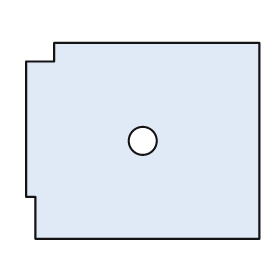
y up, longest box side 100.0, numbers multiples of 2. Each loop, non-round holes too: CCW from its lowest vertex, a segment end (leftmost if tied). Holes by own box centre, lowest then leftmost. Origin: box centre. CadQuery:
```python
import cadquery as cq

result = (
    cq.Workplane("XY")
    .moveTo(-46.0, -42.0)
    .lineTo(50.0, -42.0)
    .lineTo(50.0, 42.0)
    .lineTo(-38.0, 42.0)
    .lineTo(-38.0, 34.0)
    .lineTo(-50.0, 34.0)
    .lineTo(-50.0, -24.0)
    .lineTo(-46.0, -24.0)
    .close()
    .moveTo(0.0, 0.0)
    .circle(6.0)
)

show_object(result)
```